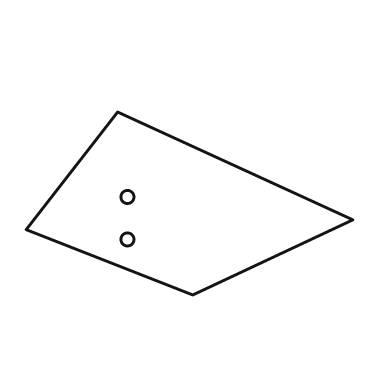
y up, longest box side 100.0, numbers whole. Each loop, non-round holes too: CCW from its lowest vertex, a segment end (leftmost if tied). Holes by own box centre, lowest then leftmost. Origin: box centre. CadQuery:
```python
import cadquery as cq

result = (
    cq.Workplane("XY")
    .moveTo(1.0, -28.0)
    .lineTo(50.0, -5.0)
    .lineTo(-22.0, 28.0)
    .lineTo(-50.0, -8.0)
    .close()
    .moveTo(-19.0, -11.0)
    .circle(2.0)
    .moveTo(-19.0, 2.0)
    .circle(2.0)
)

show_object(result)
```